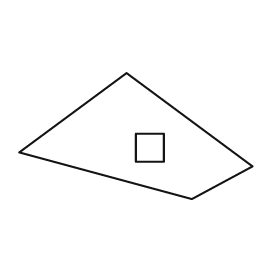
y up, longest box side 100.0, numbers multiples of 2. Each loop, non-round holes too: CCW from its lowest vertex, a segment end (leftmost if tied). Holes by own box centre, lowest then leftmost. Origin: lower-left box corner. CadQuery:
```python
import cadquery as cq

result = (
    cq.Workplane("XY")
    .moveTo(74.0, 0.0)
    .lineTo(100.0, 14.0)
    .lineTo(46.0, 54.0)
    .lineTo(0.0, 20.0)
    .close()
    .moveTo(50.0, 16.0)
    .lineTo(62.0, 16.0)
    .lineTo(62.0, 28.0)
    .lineTo(50.0, 28.0)
    .close()
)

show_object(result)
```